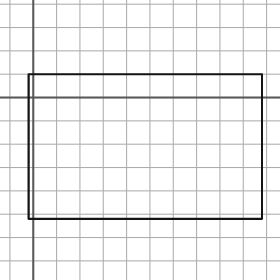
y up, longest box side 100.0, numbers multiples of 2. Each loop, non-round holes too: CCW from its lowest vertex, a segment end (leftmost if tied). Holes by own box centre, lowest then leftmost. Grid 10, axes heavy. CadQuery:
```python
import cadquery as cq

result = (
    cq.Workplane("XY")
    .moveTo(-2.0, -52.0)
    .lineTo(98.0, -52.0)
    .lineTo(98.0, 10.0)
    .lineTo(-2.0, 10.0)
    .close()
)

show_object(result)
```